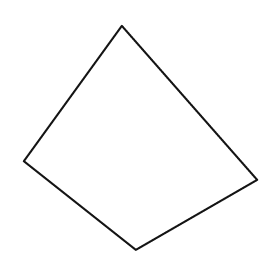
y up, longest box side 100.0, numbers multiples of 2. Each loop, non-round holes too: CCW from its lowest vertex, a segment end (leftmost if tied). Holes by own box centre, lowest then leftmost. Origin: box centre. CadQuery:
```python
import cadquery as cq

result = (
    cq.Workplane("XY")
    .moveTo(-2.0, -48.0)
    .lineTo(50.0, -18.0)
    .lineTo(-8.0, 48.0)
    .lineTo(-50.0, -10.0)
    .close()
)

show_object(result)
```